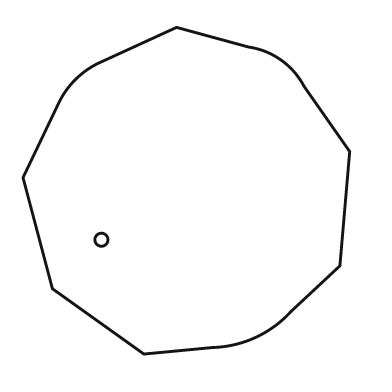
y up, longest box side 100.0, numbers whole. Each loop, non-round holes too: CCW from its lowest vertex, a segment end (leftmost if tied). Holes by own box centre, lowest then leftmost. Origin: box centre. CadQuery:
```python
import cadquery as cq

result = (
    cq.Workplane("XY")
    .moveTo(-13.0, -50.0)
    .lineTo(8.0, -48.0)
    .threePointArc((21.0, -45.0), (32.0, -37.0))
    .lineTo(47.0, -23.0)
    .lineTo(50.0, 12.0)
    .lineTo(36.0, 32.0)
    .threePointArc((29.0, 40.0), (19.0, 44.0))
    .lineTo(-3.0, 50.0)
    .lineTo(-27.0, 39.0)
    .threePointArc((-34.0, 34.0), (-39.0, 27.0))
    .lineTo(-50.0, 4.0)
    .lineTo(-41.0, -30.0)
    .close()
    .moveTo(-26.0, -15.0)
    .circle(2.0)
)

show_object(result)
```